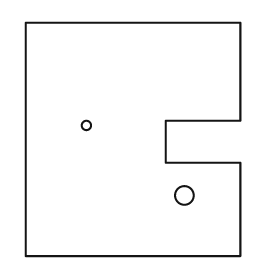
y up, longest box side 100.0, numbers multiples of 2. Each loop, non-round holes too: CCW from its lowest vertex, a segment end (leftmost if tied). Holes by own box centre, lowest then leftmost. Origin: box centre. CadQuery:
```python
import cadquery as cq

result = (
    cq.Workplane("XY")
    .moveTo(-46.0, -50.0)
    .lineTo(46.0, -50.0)
    .lineTo(46.0, -10.0)
    .lineTo(14.0, -10.0)
    .lineTo(14.0, 8.0)
    .lineTo(46.0, 8.0)
    .lineTo(46.0, 50.0)
    .lineTo(-46.0, 50.0)
    .close()
    .moveTo(22.0, -24.0)
    .circle(4.0)
    .moveTo(-20.0, 6.0)
    .circle(2.0)
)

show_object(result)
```